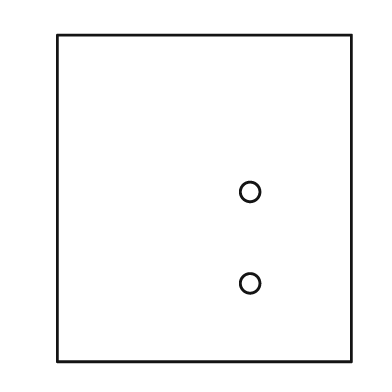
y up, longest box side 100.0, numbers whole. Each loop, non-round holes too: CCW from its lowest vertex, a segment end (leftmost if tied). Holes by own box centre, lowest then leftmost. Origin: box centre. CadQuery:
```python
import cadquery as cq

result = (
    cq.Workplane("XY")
    .moveTo(-45.0, -50.0)
    .lineTo(45.0, -50.0)
    .lineTo(45.0, 50.0)
    .lineTo(-45.0, 50.0)
    .close()
    .moveTo(14.0, -26.0)
    .circle(3.0)
    .moveTo(14.0, 2.0)
    .circle(3.0)
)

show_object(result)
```